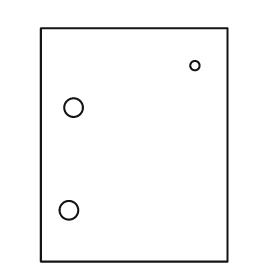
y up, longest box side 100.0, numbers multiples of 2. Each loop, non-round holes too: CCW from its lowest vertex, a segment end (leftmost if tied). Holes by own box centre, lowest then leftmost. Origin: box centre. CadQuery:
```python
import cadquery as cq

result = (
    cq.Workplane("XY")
    .moveTo(-40.0, -50.0)
    .lineTo(40.0, -50.0)
    .lineTo(40.0, 50.0)
    .lineTo(-40.0, 50.0)
    .close()
    .moveTo(-28.0, -28.0)
    .circle(4.0)
    .moveTo(-26.0, 16.0)
    .circle(4.0)
    .moveTo(26.0, 34.0)
    .circle(2.0)
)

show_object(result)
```